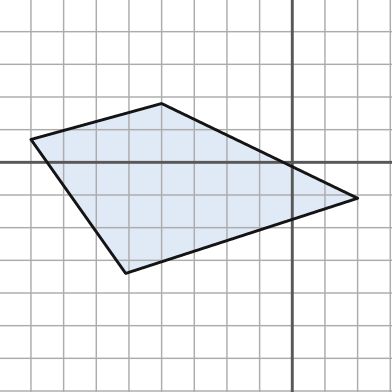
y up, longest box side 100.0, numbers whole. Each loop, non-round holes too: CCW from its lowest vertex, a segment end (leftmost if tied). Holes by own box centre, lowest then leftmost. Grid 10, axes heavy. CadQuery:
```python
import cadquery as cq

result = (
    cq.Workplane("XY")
    .moveTo(-51.0, -34.0)
    .lineTo(20.0, -11.0)
    .lineTo(-40.0, 18.0)
    .lineTo(-80.0, 7.0)
    .close()
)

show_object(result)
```